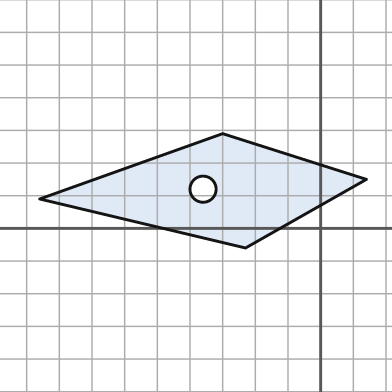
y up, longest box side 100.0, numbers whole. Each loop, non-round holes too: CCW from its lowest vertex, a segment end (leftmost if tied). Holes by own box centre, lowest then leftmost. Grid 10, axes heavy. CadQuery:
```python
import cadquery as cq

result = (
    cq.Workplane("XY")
    .moveTo(-23.0, -6.0)
    .lineTo(14.0, 15.0)
    .lineTo(-30.0, 29.0)
    .lineTo(-86.0, 9.0)
    .close()
    .moveTo(-36.0, 12.0)
    .circle(4.0)
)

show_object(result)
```